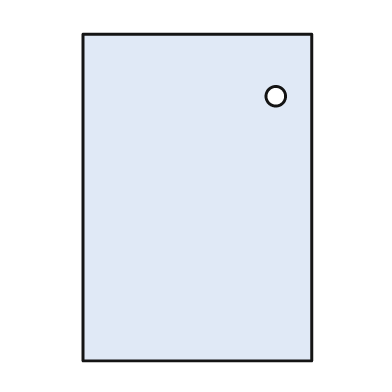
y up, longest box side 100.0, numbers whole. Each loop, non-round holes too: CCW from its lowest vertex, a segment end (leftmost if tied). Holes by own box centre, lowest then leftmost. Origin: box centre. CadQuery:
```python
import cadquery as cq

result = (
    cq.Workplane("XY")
    .moveTo(-35.0, -50.0)
    .lineTo(35.0, -50.0)
    .lineTo(35.0, 50.0)
    .lineTo(-35.0, 50.0)
    .close()
    .moveTo(24.0, 31.0)
    .circle(3.0)
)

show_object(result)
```